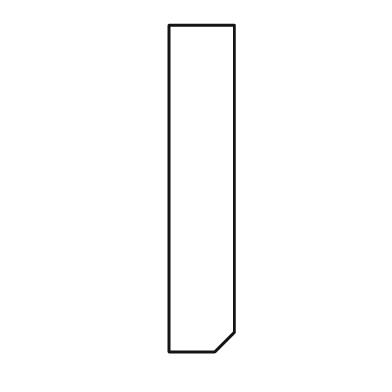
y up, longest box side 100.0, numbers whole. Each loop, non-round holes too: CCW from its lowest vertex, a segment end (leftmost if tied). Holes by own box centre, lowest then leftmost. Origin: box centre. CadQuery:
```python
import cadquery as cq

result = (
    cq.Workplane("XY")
    .moveTo(-10.0, -50.0)
    .lineTo(4.0, -50.0)
    .lineTo(10.0, -44.0)
    .lineTo(10.0, 50.0)
    .lineTo(-10.0, 50.0)
    .close()
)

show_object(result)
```